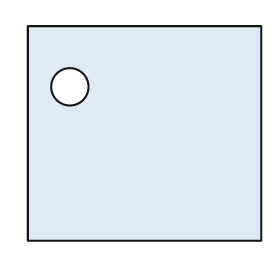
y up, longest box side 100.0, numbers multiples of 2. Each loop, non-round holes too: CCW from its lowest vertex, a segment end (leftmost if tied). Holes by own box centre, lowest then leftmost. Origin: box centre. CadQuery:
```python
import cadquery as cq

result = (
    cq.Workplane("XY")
    .moveTo(-50.0, -46.0)
    .lineTo(50.0, -46.0)
    .lineTo(50.0, 46.0)
    .lineTo(-50.0, 46.0)
    .close()
    .moveTo(-32.0, 20.0)
    .circle(8.0)
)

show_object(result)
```